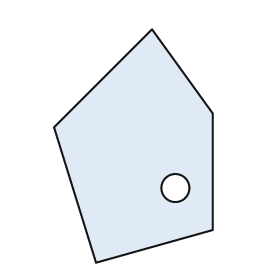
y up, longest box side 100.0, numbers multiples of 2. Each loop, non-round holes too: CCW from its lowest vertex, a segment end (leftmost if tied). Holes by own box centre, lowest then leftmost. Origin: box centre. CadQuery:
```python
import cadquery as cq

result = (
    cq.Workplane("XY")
    .moveTo(-16.0, -50.0)
    .lineTo(34.0, -36.0)
    .lineTo(34.0, 14.0)
    .lineTo(8.0, 50.0)
    .lineTo(-34.0, 8.0)
    .close()
    .moveTo(18.0, -18.0)
    .circle(6.0)
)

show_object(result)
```